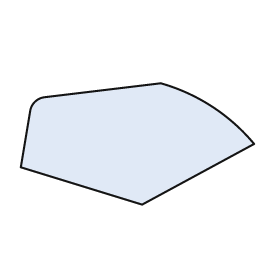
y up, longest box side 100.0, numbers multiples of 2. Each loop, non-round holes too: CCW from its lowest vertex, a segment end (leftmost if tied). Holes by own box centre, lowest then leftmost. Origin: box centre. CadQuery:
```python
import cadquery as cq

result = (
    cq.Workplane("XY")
    .moveTo(2.0, -26.0)
    .lineTo(50.0, 0.0)
    .threePointArc((32.0, 16.0), (10.0, 26.0))
    .lineTo(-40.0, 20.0)
    .threePointArc((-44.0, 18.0), (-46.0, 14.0))
    .lineTo(-50.0, -10.0)
    .close()
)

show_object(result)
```